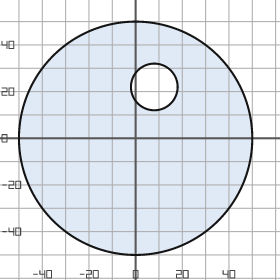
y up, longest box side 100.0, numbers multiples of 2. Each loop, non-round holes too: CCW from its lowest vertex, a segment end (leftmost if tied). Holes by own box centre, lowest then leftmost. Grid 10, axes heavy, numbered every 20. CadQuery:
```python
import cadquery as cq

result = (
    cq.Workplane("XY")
    .moveTo(0.0, 0.0)
    .circle(50.0)
    .moveTo(8.0, 22.0)
    .circle(10.0)
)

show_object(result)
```